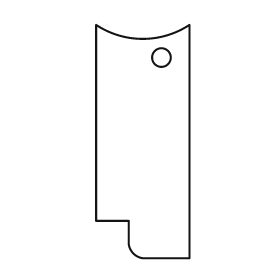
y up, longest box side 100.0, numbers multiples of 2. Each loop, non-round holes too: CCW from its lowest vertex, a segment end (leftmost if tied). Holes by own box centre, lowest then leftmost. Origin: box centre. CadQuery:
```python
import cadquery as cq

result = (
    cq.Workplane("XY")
    .moveTo(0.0, -50.0)
    .lineTo(20.0, -50.0)
    .lineTo(20.0, 50.0)
    .threePointArc((0.0, 44.0), (-20.0, 50.0))
    .lineTo(-20.0, -34.0)
    .lineTo(-6.0, -34.0)
    .lineTo(-6.0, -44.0)
    .threePointArc((-4.0, -48.0), (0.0, -50.0))
    .close()
    .moveTo(8.0, 36.0)
    .circle(4.0)
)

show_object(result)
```